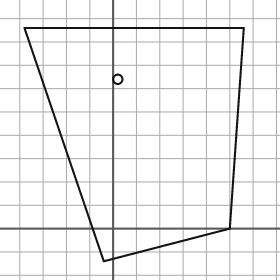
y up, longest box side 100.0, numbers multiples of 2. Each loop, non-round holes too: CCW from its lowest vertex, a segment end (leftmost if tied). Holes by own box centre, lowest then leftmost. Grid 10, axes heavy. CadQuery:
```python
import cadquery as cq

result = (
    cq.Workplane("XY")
    .moveTo(-4.0, -14.0)
    .lineTo(50.0, 0.0)
    .lineTo(56.0, 86.0)
    .lineTo(-38.0, 86.0)
    .close()
    .moveTo(2.0, 64.0)
    .circle(2.0)
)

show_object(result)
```